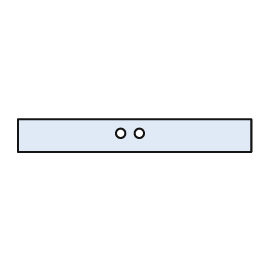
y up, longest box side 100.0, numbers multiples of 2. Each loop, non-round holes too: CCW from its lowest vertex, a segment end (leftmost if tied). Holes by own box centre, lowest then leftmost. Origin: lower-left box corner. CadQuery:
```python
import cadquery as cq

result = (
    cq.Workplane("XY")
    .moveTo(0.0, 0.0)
    .lineTo(100.0, 0.0)
    .lineTo(100.0, 14.0)
    .lineTo(0.0, 14.0)
    .close()
    .moveTo(44.0, 8.0)
    .circle(2.0)
    .moveTo(52.0, 8.0)
    .circle(2.0)
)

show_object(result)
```